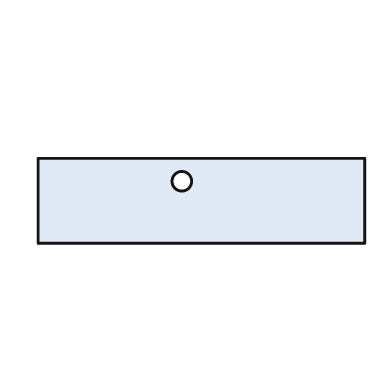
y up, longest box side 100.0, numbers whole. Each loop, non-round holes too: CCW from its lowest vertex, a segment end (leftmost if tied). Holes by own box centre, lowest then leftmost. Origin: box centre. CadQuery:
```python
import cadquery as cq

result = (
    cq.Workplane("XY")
    .moveTo(-50.0, -13.0)
    .lineTo(50.0, -13.0)
    .lineTo(50.0, 13.0)
    .lineTo(-50.0, 13.0)
    .close()
    .moveTo(-6.0, 6.0)
    .circle(3.0)
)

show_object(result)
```